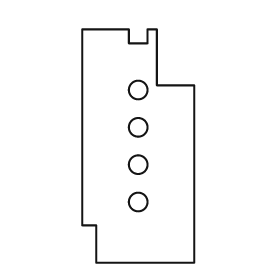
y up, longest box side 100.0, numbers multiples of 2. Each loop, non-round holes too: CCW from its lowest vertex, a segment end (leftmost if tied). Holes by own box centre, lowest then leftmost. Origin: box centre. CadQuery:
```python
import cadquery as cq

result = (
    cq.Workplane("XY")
    .moveTo(-18.0, -50.0)
    .lineTo(24.0, -50.0)
    .lineTo(24.0, 26.0)
    .lineTo(8.0, 26.0)
    .lineTo(8.0, 50.0)
    .lineTo(4.0, 50.0)
    .lineTo(4.0, 44.0)
    .lineTo(-4.0, 44.0)
    .lineTo(-4.0, 50.0)
    .lineTo(-24.0, 50.0)
    .lineTo(-24.0, -34.0)
    .lineTo(-18.0, -34.0)
    .close()
    .moveTo(0.0, -24.0)
    .circle(4.0)
    .moveTo(0.0, -8.0)
    .circle(4.0)
    .moveTo(0.0, 8.0)
    .circle(4.0)
    .moveTo(0.0, 24.0)
    .circle(4.0)
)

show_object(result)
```